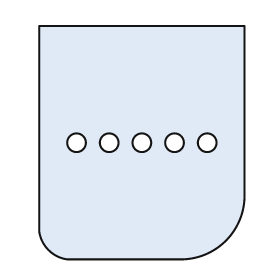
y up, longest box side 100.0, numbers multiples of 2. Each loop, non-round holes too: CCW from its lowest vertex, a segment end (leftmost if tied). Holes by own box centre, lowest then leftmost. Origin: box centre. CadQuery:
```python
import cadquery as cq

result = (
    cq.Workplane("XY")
    .moveTo(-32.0, -50.0)
    .lineTo(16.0, -50.0)
    .threePointArc((36.0, -42.0), (44.0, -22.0))
    .lineTo(44.0, 50.0)
    .lineTo(-44.0, 50.0)
    .lineTo(-44.0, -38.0)
    .threePointArc((-40.0, -46.0), (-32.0, -50.0))
    .close()
    .moveTo(-28.0, 0.0)
    .circle(4.0)
    .moveTo(-14.0, 0.0)
    .circle(4.0)
    .moveTo(0.0, 0.0)
    .circle(4.0)
    .moveTo(14.0, 0.0)
    .circle(4.0)
    .moveTo(28.0, 0.0)
    .circle(4.0)
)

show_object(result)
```